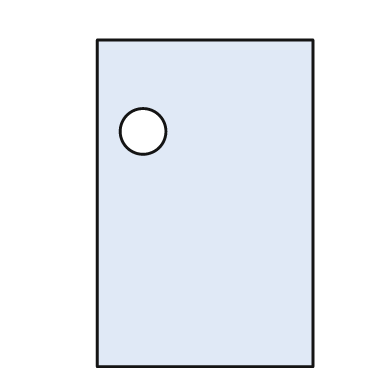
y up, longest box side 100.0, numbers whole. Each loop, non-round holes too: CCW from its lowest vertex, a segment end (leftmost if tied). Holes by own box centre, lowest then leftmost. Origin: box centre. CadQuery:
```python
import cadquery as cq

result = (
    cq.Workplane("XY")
    .moveTo(-33.0, -50.0)
    .lineTo(33.0, -50.0)
    .lineTo(33.0, 50.0)
    .lineTo(-33.0, 50.0)
    .close()
    .moveTo(-19.0, 22.0)
    .circle(7.0)
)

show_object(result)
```